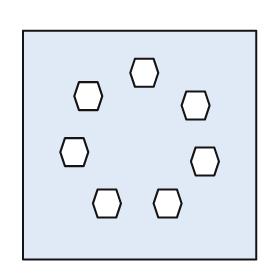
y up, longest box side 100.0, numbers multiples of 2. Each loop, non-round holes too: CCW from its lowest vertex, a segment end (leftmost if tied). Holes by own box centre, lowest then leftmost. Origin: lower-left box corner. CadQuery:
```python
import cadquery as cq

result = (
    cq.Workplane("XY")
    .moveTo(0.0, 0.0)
    .lineTo(100.0, 0.0)
    .lineTo(100.0, 98.0)
    .lineTo(0.0, 98.0)
    .close()
    .moveTo(32.0, 18.0)
    .lineTo(40.0, 18.0)
    .lineTo(42.0, 24.0)
    .lineTo(40.0, 30.0)
    .lineTo(32.0, 30.0)
    .lineTo(30.0, 24.0)
    .close()
    .moveTo(58.0, 18.0)
    .lineTo(66.0, 18.0)
    .lineTo(68.0, 24.0)
    .lineTo(66.0, 30.0)
    .lineTo(58.0, 30.0)
    .lineTo(56.0, 24.0)
    .close()
    .moveTo(74.0, 36.0)
    .lineTo(82.0, 36.0)
    .lineTo(84.0, 42.0)
    .lineTo(82.0, 48.0)
    .lineTo(74.0, 48.0)
    .lineTo(72.0, 42.0)
    .close()
    .moveTo(18.0, 40.0)
    .lineTo(26.0, 40.0)
    .lineTo(28.0, 46.0)
    .lineTo(26.0, 52.0)
    .lineTo(18.0, 52.0)
    .lineTo(16.0, 46.0)
    .close()
    .moveTo(70.0, 60.0)
    .lineTo(78.0, 60.0)
    .lineTo(80.0, 66.0)
    .lineTo(78.0, 72.0)
    .lineTo(70.0, 72.0)
    .lineTo(68.0, 66.0)
    .close()
    .moveTo(24.0, 64.0)
    .lineTo(32.0, 64.0)
    .lineTo(34.0, 70.0)
    .lineTo(32.0, 76.0)
    .lineTo(24.0, 76.0)
    .lineTo(22.0, 70.0)
    .close()
    .moveTo(48.0, 74.0)
    .lineTo(56.0, 74.0)
    .lineTo(58.0, 80.0)
    .lineTo(56.0, 86.0)
    .lineTo(48.0, 86.0)
    .lineTo(46.0, 80.0)
    .close()
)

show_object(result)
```